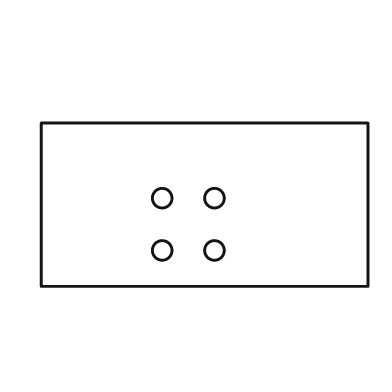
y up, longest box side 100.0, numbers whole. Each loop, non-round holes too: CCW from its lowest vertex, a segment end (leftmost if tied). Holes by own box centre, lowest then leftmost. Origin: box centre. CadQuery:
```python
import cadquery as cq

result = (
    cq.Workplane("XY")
    .moveTo(-50.0, -25.0)
    .lineTo(50.0, -25.0)
    .lineTo(50.0, 25.0)
    .lineTo(-50.0, 25.0)
    .close()
    .moveTo(-13.0, -14.0)
    .circle(3.0)
    .moveTo(3.0, -14.0)
    .circle(3.0)
    .moveTo(-13.0, 2.0)
    .circle(3.0)
    .moveTo(3.0, 2.0)
    .circle(3.0)
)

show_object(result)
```